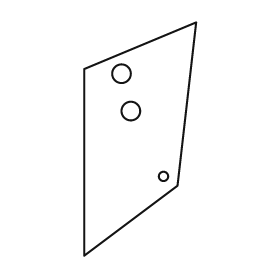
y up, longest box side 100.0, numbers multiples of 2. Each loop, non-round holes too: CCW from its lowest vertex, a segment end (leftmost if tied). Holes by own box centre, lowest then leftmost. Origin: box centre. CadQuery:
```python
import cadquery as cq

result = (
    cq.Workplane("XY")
    .moveTo(-24.0, -50.0)
    .lineTo(16.0, -20.0)
    .lineTo(24.0, 50.0)
    .lineTo(-24.0, 30.0)
    .close()
    .moveTo(10.0, -16.0)
    .circle(2.0)
    .moveTo(-4.0, 12.0)
    .circle(4.0)
    .moveTo(-8.0, 28.0)
    .circle(4.0)
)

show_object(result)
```